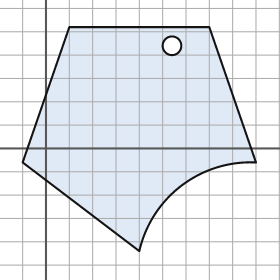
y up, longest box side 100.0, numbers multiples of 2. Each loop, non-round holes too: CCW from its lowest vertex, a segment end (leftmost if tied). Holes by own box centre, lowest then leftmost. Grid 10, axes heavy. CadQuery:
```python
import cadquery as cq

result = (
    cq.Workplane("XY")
    .moveTo(40.0, -44.0)
    .threePointArc((58.0, -16.0), (90.0, -6.0))
    .lineTo(70.0, 52.0)
    .lineTo(10.0, 52.0)
    .lineTo(-10.0, -6.0)
    .close()
    .moveTo(54.0, 44.0)
    .circle(4.0)
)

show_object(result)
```